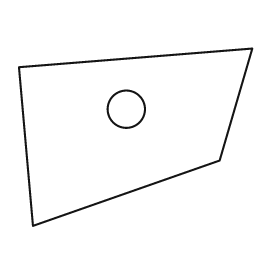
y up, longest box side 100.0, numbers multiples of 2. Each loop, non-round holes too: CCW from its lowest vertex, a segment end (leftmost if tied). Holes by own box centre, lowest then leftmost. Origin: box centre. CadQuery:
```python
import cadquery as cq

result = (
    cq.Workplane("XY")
    .moveTo(-44.0, -38.0)
    .lineTo(36.0, -10.0)
    .lineTo(50.0, 38.0)
    .lineTo(-50.0, 30.0)
    .close()
    .moveTo(-4.0, 12.0)
    .circle(8.0)
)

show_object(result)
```